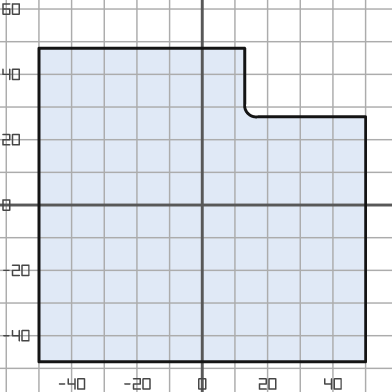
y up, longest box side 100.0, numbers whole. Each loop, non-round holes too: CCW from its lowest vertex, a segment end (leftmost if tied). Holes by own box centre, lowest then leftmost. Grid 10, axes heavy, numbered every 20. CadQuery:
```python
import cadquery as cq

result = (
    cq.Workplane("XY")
    .moveTo(-50.0, -48.0)
    .lineTo(50.0, -48.0)
    .lineTo(50.0, 27.0)
    .lineTo(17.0, 27.0)
    .threePointArc((14.0, 28.0), (13.0, 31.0))
    .lineTo(13.0, 48.0)
    .lineTo(-50.0, 48.0)
    .close()
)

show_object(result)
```